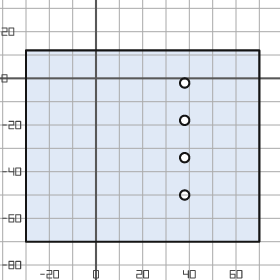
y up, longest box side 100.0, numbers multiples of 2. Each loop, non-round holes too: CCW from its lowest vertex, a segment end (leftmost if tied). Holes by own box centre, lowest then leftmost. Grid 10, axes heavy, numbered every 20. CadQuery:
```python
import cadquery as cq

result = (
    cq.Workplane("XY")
    .moveTo(-30.0, -70.0)
    .lineTo(70.0, -70.0)
    .lineTo(70.0, 12.0)
    .lineTo(-30.0, 12.0)
    .close()
    .moveTo(38.0, -50.0)
    .circle(2.0)
    .moveTo(38.0, -34.0)
    .circle(2.0)
    .moveTo(38.0, -18.0)
    .circle(2.0)
    .moveTo(38.0, -2.0)
    .circle(2.0)
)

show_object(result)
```